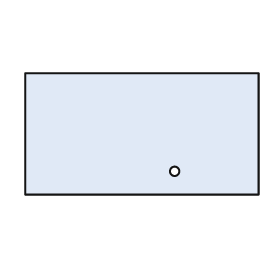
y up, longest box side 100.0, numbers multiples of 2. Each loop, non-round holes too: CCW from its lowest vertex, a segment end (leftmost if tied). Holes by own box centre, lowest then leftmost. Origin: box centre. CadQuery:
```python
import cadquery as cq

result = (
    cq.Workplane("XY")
    .moveTo(-50.0, -26.0)
    .lineTo(50.0, -26.0)
    .lineTo(50.0, 26.0)
    .lineTo(-50.0, 26.0)
    .close()
    .moveTo(14.0, -16.0)
    .circle(2.0)
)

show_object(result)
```